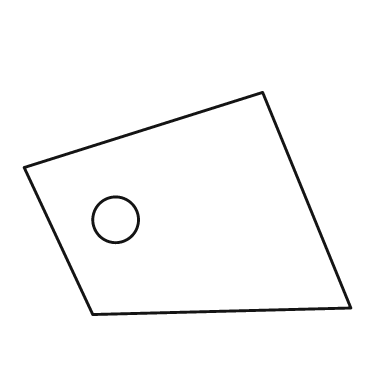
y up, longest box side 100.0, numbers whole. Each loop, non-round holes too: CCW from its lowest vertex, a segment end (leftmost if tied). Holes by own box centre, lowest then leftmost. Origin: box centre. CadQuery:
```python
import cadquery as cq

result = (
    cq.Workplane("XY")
    .moveTo(-29.0, -34.0)
    .lineTo(50.0, -32.0)
    .lineTo(23.0, 34.0)
    .lineTo(-50.0, 11.0)
    .close()
    .moveTo(-22.0, -5.0)
    .circle(7.0)
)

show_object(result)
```